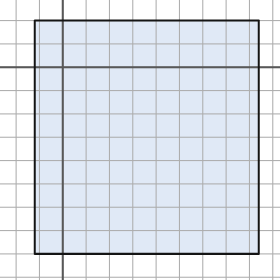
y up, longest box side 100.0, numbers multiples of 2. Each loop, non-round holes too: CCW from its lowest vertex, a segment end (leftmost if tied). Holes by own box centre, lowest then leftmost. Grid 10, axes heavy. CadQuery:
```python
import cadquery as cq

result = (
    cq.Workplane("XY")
    .moveTo(-12.0, -80.0)
    .lineTo(84.0, -80.0)
    .lineTo(84.0, 20.0)
    .lineTo(-12.0, 20.0)
    .close()
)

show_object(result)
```